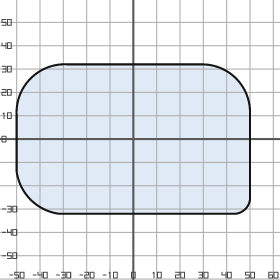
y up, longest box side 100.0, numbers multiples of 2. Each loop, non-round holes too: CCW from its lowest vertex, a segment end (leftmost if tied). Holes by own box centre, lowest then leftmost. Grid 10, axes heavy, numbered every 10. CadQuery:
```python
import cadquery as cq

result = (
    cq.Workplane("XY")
    .moveTo(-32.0, -32.0)
    .lineTo(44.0, -32.0)
    .threePointArc((48.0, -30.0), (50.0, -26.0))
    .lineTo(50.0, 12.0)
    .threePointArc((44.0, 26.0), (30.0, 32.0))
    .lineTo(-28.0, 32.0)
    .threePointArc((-44.0, 26.0), (-50.0, 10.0))
    .lineTo(-50.0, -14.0)
    .threePointArc((-44.0, -26.0), (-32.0, -32.0))
    .close()
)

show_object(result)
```